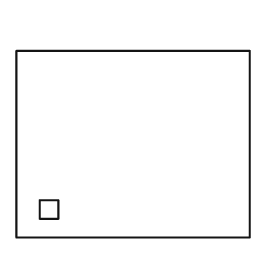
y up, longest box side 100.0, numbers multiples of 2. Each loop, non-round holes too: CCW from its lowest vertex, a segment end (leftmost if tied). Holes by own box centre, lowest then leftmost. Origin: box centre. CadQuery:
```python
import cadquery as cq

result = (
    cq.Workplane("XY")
    .moveTo(-50.0, -40.0)
    .lineTo(50.0, -40.0)
    .lineTo(50.0, 40.0)
    .lineTo(-50.0, 40.0)
    .close()
    .moveTo(-40.0, -32.0)
    .lineTo(-32.0, -32.0)
    .lineTo(-32.0, -24.0)
    .lineTo(-40.0, -24.0)
    .close()
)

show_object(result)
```